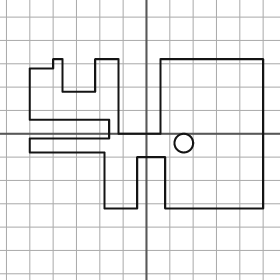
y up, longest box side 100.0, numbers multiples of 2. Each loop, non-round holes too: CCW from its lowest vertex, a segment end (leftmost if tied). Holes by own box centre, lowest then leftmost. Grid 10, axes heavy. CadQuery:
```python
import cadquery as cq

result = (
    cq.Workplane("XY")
    .moveTo(-18.0, -32.0)
    .lineTo(-4.0, -32.0)
    .lineTo(-4.0, -10.0)
    .lineTo(8.0, -10.0)
    .lineTo(8.0, -32.0)
    .lineTo(50.0, -32.0)
    .lineTo(50.0, 32.0)
    .lineTo(6.0, 32.0)
    .lineTo(6.0, 0.0)
    .lineTo(-12.0, 0.0)
    .lineTo(-12.0, 32.0)
    .lineTo(-22.0, 32.0)
    .lineTo(-22.0, 18.0)
    .lineTo(-36.0, 18.0)
    .lineTo(-36.0, 32.0)
    .lineTo(-40.0, 32.0)
    .lineTo(-40.0, 28.0)
    .lineTo(-50.0, 28.0)
    .lineTo(-50.0, 6.0)
    .lineTo(-16.0, 6.0)
    .lineTo(-16.0, -2.0)
    .lineTo(-50.0, -2.0)
    .lineTo(-50.0, -8.0)
    .lineTo(-18.0, -8.0)
    .close()
    .moveTo(16.0, -4.0)
    .circle(4.0)
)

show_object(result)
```